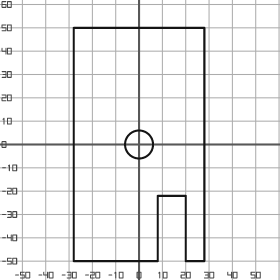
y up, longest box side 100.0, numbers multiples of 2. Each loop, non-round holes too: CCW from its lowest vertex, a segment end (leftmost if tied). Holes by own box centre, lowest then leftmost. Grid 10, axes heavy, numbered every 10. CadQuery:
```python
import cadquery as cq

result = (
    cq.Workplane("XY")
    .moveTo(-28.0, -50.0)
    .lineTo(8.0, -50.0)
    .lineTo(8.0, -22.0)
    .lineTo(20.0, -22.0)
    .lineTo(20.0, -50.0)
    .lineTo(28.0, -50.0)
    .lineTo(28.0, 50.0)
    .lineTo(-28.0, 50.0)
    .close()
    .moveTo(0.0, 0.0)
    .circle(6.0)
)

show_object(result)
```